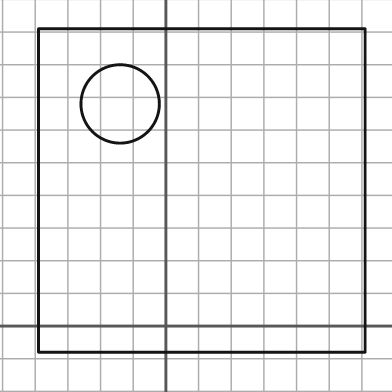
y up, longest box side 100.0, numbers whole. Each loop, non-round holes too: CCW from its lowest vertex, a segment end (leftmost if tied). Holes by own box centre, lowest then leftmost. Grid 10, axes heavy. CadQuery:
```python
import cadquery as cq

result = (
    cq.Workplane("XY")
    .moveTo(-39.0, -8.0)
    .lineTo(61.0, -8.0)
    .lineTo(61.0, 91.0)
    .lineTo(-39.0, 91.0)
    .close()
    .moveTo(-14.0, 68.0)
    .circle(12.0)
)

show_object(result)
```